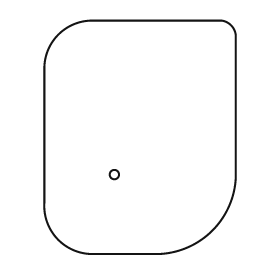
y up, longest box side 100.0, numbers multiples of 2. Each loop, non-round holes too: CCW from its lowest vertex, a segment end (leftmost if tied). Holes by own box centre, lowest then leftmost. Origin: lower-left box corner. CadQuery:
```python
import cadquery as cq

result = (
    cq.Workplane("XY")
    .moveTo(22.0, 0.0)
    .lineTo(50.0, 0.0)
    .threePointArc((72.0, 10.0), (82.0, 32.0))
    .lineTo(82.0, 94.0)
    .threePointArc((80.0, 98.0), (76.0, 100.0))
    .lineTo(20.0, 100.0)
    .threePointArc((6.0, 94.0), (0.0, 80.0))
    .lineTo(0.0, 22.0)
    .threePointArc((6.0, 6.0), (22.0, 0.0))
    .close()
    .moveTo(30.0, 34.0)
    .circle(2.0)
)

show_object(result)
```